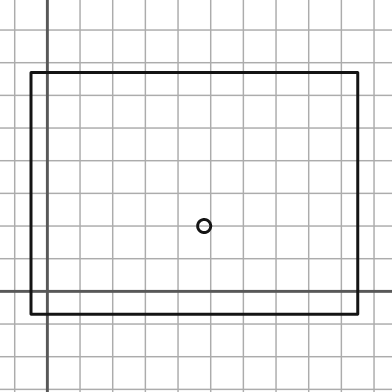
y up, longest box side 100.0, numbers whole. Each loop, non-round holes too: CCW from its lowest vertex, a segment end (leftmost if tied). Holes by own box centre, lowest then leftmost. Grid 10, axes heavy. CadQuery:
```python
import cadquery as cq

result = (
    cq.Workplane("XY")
    .moveTo(-5.0, -7.0)
    .lineTo(95.0, -7.0)
    .lineTo(95.0, 67.0)
    .lineTo(-5.0, 67.0)
    .close()
    .moveTo(48.0, 20.0)
    .circle(2.0)
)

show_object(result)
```